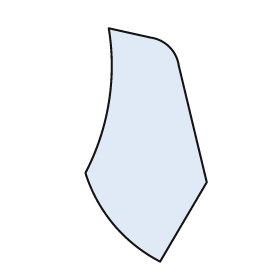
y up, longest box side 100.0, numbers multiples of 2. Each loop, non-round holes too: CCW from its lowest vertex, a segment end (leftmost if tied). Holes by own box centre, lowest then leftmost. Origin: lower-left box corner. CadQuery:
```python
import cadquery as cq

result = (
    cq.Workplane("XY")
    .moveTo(32.0, 0.0)
    .lineTo(52.0, 34.0)
    .lineTo(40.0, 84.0)
    .threePointArc((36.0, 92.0), (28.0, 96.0))
    .lineTo(10.0, 100.0)
    .threePointArc((10.0, 68.0), (0.0, 38.0))
    .threePointArc((12.0, 16.0), (32.0, 0.0))
    .close()
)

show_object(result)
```